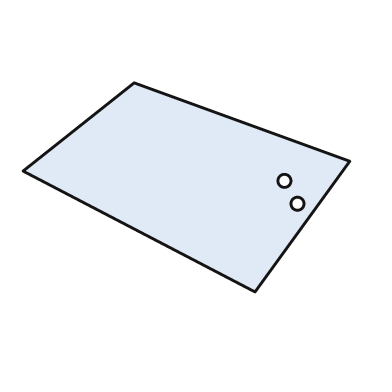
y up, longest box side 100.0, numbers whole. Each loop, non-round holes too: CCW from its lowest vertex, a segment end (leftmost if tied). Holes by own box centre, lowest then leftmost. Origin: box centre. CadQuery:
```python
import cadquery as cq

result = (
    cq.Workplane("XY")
    .moveTo(21.0, -32.0)
    .lineTo(50.0, 8.0)
    .lineTo(-16.0, 32.0)
    .lineTo(-50.0, 5.0)
    .close()
    .moveTo(34.0, -5.0)
    .circle(2.0)
    .moveTo(30.0, 2.0)
    .circle(2.0)
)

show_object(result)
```